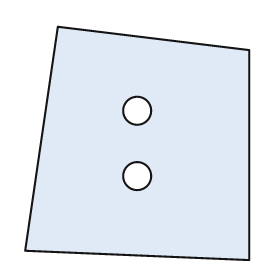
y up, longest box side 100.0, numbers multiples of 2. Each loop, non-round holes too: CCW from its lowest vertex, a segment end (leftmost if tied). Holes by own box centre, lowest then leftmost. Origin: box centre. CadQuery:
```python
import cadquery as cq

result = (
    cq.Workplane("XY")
    .moveTo(48.0, -50.0)
    .lineTo(48.0, 40.0)
    .lineTo(-34.0, 50.0)
    .lineTo(-48.0, -46.0)
    .close()
    .moveTo(0.0, -14.0)
    .circle(6.0)
    .moveTo(0.0, 14.0)
    .circle(6.0)
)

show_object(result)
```